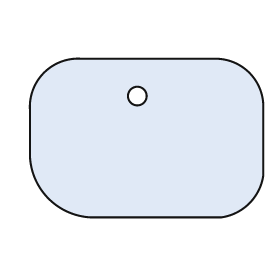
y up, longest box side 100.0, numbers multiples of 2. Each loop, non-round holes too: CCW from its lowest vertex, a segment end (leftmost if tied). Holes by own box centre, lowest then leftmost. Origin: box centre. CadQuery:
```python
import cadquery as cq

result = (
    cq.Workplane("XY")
    .moveTo(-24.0, -34.0)
    .lineTo(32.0, -34.0)
    .threePointArc((44.0, -28.0), (50.0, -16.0))
    .lineTo(50.0, 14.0)
    .threePointArc((44.0, 28.0), (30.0, 34.0))
    .lineTo(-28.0, 34.0)
    .threePointArc((-44.0, 28.0), (-50.0, 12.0))
    .lineTo(-50.0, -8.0)
    .threePointArc((-42.0, -26.0), (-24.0, -34.0))
    .close()
    .moveTo(-4.0, 18.0)
    .circle(4.0)
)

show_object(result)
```